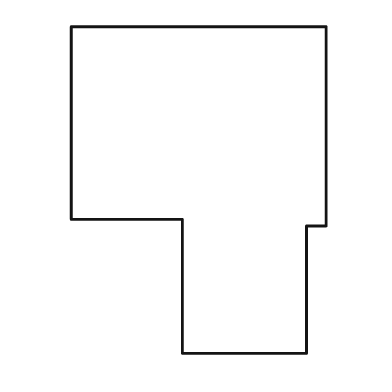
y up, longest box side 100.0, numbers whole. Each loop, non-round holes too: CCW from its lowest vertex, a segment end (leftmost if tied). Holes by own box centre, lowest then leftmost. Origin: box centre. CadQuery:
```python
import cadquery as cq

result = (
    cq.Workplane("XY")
    .moveTo(-5.0, -50.0)
    .lineTo(33.0, -50.0)
    .lineTo(33.0, -11.0)
    .lineTo(39.0, -11.0)
    .lineTo(39.0, 50.0)
    .lineTo(-39.0, 50.0)
    .lineTo(-39.0, -9.0)
    .lineTo(-5.0, -9.0)
    .close()
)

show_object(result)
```